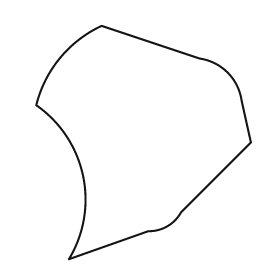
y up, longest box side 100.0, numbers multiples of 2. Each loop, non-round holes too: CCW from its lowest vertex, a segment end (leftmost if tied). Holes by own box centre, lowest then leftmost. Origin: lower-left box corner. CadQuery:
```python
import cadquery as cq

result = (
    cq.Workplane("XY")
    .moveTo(14.0, 0.0)
    .lineTo(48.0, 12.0)
    .threePointArc((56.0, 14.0), (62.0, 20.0))
    .lineTo(92.0, 50.0)
    .lineTo(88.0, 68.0)
    .threePointArc((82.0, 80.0), (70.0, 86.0))
    .lineTo(28.0, 100.0)
    .threePointArc((10.0, 86.0), (0.0, 66.0))
    .threePointArc((20.0, 36.0), (14.0, 0.0))
    .close()
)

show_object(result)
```